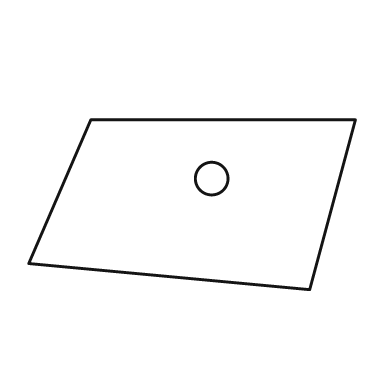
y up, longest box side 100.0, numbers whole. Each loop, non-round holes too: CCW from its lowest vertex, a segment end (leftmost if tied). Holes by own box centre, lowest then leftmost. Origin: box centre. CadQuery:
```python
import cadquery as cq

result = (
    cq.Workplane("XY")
    .moveTo(36.0, -26.0)
    .lineTo(50.0, 26.0)
    .lineTo(-31.0, 26.0)
    .lineTo(-50.0, -18.0)
    .close()
    .moveTo(6.0, 8.0)
    .circle(5.0)
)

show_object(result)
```